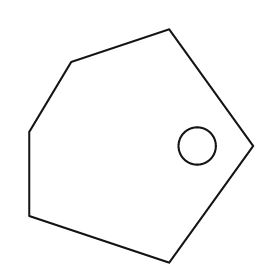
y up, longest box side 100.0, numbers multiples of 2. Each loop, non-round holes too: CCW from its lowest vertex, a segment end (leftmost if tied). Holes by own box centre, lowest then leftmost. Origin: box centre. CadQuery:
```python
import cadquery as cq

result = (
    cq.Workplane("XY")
    .moveTo(12.0, -50.0)
    .lineTo(48.0, 0.0)
    .lineTo(12.0, 50.0)
    .lineTo(-30.0, 36.0)
    .lineTo(-48.0, 6.0)
    .lineTo(-48.0, -30.0)
    .close()
    .moveTo(24.0, 0.0)
    .circle(8.0)
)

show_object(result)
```